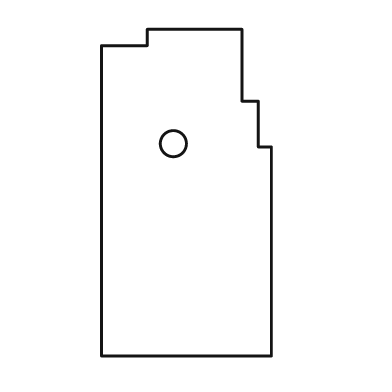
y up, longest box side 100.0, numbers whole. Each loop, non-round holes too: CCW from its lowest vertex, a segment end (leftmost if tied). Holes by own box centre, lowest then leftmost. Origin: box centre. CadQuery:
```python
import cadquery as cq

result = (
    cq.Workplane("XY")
    .moveTo(-26.0, -50.0)
    .lineTo(26.0, -50.0)
    .lineTo(26.0, 14.0)
    .lineTo(22.0, 14.0)
    .lineTo(22.0, 28.0)
    .lineTo(17.0, 28.0)
    .lineTo(17.0, 50.0)
    .lineTo(-12.0, 50.0)
    .lineTo(-12.0, 45.0)
    .lineTo(-26.0, 45.0)
    .close()
    .moveTo(-4.0, 15.0)
    .circle(4.0)
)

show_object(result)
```